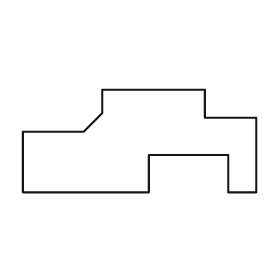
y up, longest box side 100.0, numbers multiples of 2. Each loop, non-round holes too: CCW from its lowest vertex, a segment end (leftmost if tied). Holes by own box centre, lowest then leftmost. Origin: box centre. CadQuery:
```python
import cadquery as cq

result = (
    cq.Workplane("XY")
    .moveTo(-50.0, -22.0)
    .lineTo(4.0, -22.0)
    .lineTo(4.0, -6.0)
    .lineTo(38.0, -6.0)
    .lineTo(38.0, -22.0)
    .lineTo(50.0, -22.0)
    .lineTo(50.0, 10.0)
    .lineTo(28.0, 10.0)
    .lineTo(28.0, 22.0)
    .lineTo(-16.0, 22.0)
    .lineTo(-16.0, 12.0)
    .lineTo(-24.0, 4.0)
    .lineTo(-50.0, 4.0)
    .close()
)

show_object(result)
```